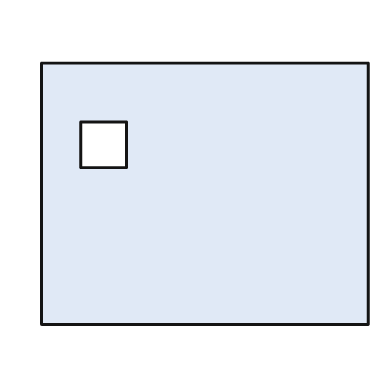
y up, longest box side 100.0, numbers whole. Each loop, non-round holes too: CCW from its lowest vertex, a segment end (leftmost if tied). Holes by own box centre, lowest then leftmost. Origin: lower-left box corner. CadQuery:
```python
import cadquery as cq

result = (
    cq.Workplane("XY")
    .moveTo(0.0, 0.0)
    .lineTo(100.0, 0.0)
    .lineTo(100.0, 80.0)
    .lineTo(0.0, 80.0)
    .close()
    .moveTo(12.0, 48.0)
    .lineTo(26.0, 48.0)
    .lineTo(26.0, 62.0)
    .lineTo(12.0, 62.0)
    .close()
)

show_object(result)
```